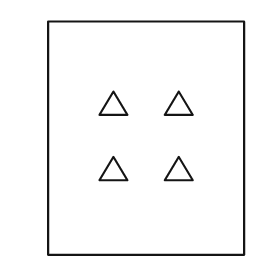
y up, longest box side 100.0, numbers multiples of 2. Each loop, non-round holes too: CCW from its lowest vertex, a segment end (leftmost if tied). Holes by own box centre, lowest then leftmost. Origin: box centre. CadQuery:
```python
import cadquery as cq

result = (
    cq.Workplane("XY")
    .moveTo(-42.0, -50.0)
    .lineTo(42.0, -50.0)
    .lineTo(42.0, 50.0)
    .lineTo(-42.0, 50.0)
    .close()
    .moveTo(-20.0, -18.0)
    .lineTo(-8.0, -18.0)
    .lineTo(-14.0, -8.0)
    .close()
    .moveTo(8.0, -18.0)
    .lineTo(20.0, -18.0)
    .lineTo(14.0, -8.0)
    .close()
    .moveTo(-20.0, 10.0)
    .lineTo(-8.0, 10.0)
    .lineTo(-14.0, 20.0)
    .close()
    .moveTo(8.0, 10.0)
    .lineTo(20.0, 10.0)
    .lineTo(14.0, 20.0)
    .close()
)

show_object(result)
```